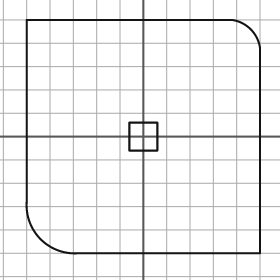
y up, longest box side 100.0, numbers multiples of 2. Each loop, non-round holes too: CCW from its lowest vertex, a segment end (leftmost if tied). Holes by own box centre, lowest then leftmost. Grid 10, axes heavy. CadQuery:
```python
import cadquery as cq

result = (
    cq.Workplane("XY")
    .moveTo(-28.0, -50.0)
    .lineTo(50.0, -50.0)
    .lineTo(50.0, 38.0)
    .threePointArc((46.0, 46.0), (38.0, 50.0))
    .lineTo(-50.0, 50.0)
    .lineTo(-50.0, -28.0)
    .threePointArc((-44.0, -44.0), (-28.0, -50.0))
    .close()
    .moveTo(-6.0, -6.0)
    .lineTo(6.0, -6.0)
    .lineTo(6.0, 6.0)
    .lineTo(-6.0, 6.0)
    .close()
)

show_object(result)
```